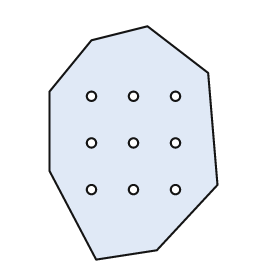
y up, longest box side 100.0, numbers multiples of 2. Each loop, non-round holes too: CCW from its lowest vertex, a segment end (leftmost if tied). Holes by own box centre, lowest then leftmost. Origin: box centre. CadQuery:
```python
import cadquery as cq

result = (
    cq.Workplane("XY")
    .moveTo(-16.0, -50.0)
    .lineTo(10.0, -46.0)
    .lineTo(36.0, -18.0)
    .lineTo(32.0, 30.0)
    .lineTo(6.0, 50.0)
    .lineTo(-18.0, 44.0)
    .lineTo(-36.0, 22.0)
    .lineTo(-36.0, -12.0)
    .close()
    .moveTo(-18.0, -20.0)
    .circle(2.0)
    .moveTo(0.0, -20.0)
    .circle(2.0)
    .moveTo(18.0, -20.0)
    .circle(2.0)
    .moveTo(-18.0, 0.0)
    .circle(2.0)
    .moveTo(0.0, 0.0)
    .circle(2.0)
    .moveTo(18.0, 0.0)
    .circle(2.0)
    .moveTo(-18.0, 20.0)
    .circle(2.0)
    .moveTo(0.0, 20.0)
    .circle(2.0)
    .moveTo(18.0, 20.0)
    .circle(2.0)
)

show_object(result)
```